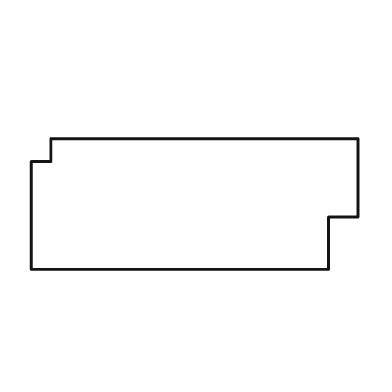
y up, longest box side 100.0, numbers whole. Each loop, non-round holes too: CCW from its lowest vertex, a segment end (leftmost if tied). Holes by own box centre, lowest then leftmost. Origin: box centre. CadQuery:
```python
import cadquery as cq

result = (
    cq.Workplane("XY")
    .moveTo(-50.0, -20.0)
    .lineTo(41.0, -20.0)
    .lineTo(41.0, -4.0)
    .lineTo(50.0, -4.0)
    .lineTo(50.0, 20.0)
    .lineTo(-44.0, 20.0)
    .lineTo(-44.0, 13.0)
    .lineTo(-50.0, 13.0)
    .close()
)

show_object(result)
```